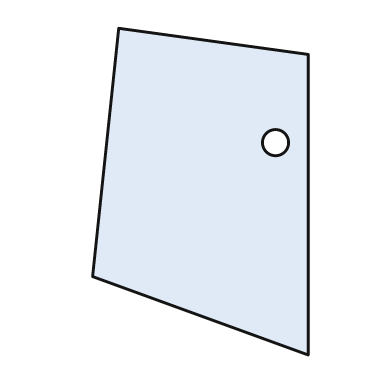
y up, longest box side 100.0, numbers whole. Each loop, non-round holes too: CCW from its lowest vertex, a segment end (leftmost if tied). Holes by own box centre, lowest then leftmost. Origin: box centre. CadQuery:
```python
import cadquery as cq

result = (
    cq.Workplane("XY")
    .moveTo(33.0, -50.0)
    .lineTo(33.0, 42.0)
    .lineTo(-25.0, 50.0)
    .lineTo(-33.0, -26.0)
    .close()
    .moveTo(23.0, 15.0)
    .circle(4.0)
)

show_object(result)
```